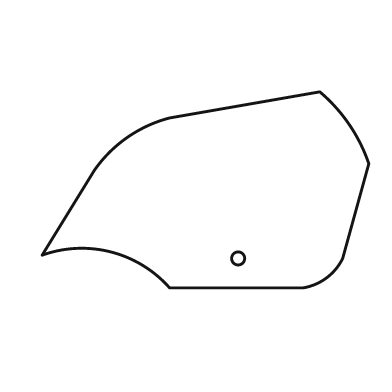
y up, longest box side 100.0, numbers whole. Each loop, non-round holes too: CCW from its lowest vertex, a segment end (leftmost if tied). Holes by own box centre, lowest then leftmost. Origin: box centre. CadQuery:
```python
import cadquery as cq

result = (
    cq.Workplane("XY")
    .moveTo(-11.0, -30.0)
    .lineTo(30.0, -30.0)
    .threePointArc((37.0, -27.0), (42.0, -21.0))
    .lineTo(50.0, 8.0)
    .threePointArc((44.0, 20.0), (35.0, 30.0))
    .lineTo(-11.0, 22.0)
    .threePointArc((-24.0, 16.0), (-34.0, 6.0))
    .lineTo(-50.0, -20.0)
    .threePointArc((-29.0, -19.0), (-11.0, -30.0))
    .close()
    .moveTo(10.0, -21.0)
    .circle(2.0)
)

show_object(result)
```